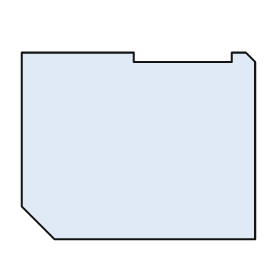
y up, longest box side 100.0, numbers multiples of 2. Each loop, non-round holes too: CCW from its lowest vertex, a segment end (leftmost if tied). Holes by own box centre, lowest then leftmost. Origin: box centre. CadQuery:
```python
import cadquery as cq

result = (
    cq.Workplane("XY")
    .moveTo(-36.0, -40.0)
    .lineTo(50.0, -40.0)
    .lineTo(50.0, 36.0)
    .lineTo(46.0, 40.0)
    .lineTo(40.0, 40.0)
    .lineTo(40.0, 36.0)
    .lineTo(-2.0, 36.0)
    .lineTo(-2.0, 40.0)
    .lineTo(-50.0, 40.0)
    .lineTo(-50.0, -26.0)
    .close()
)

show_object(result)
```